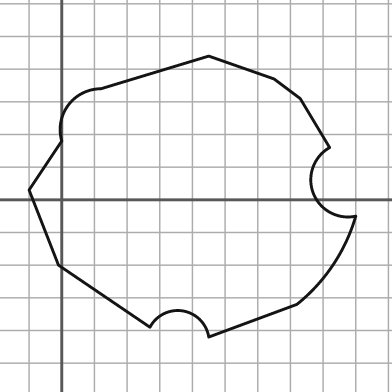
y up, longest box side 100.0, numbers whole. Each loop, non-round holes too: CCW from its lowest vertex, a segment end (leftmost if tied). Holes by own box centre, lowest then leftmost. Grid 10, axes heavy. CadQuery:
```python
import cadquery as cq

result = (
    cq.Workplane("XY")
    .moveTo(45.0, -42.0)
    .lineTo(72.0, -32.0)
    .threePointArc((83.0, -20.0), (90.0, -5.0))
    .threePointArc((77.0, 2.0), (82.0, 16.0))
    .lineTo(73.0, 31.0)
    .lineTo(65.0, 37.0)
    .lineTo(45.0, 44.0)
    .lineTo(12.0, 34.0)
    .threePointArc((2.0, 29.0), (0.0, 18.0))
    .lineTo(-10.0, 3.0)
    .lineTo(-1.0, -20.0)
    .lineTo(27.0, -39.0)
    .threePointArc((37.0, -34.0), (45.0, -42.0))
    .close()
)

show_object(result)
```